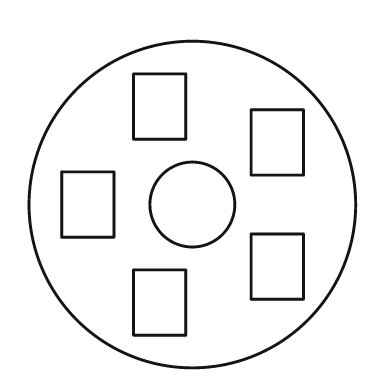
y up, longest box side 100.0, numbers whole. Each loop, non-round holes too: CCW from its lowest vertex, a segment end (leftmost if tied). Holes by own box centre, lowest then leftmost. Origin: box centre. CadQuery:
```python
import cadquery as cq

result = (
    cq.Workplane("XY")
    .moveTo(0.0, 0.0)
    .circle(50.0)
    .moveTo(-18.0, -40.0)
    .lineTo(-2.0, -40.0)
    .lineTo(-2.0, -20.0)
    .lineTo(-18.0, -20.0)
    .close()
    .moveTo(18.0, -29.0)
    .lineTo(34.0, -29.0)
    .lineTo(34.0, -9.0)
    .lineTo(18.0, -9.0)
    .close()
    .moveTo(-40.0, -10.0)
    .lineTo(-24.0, -10.0)
    .lineTo(-24.0, 10.0)
    .lineTo(-40.0, 10.0)
    .close()
    .moveTo(0.0, 0.0)
    .circle(13.0)
    .moveTo(18.0, 9.0)
    .lineTo(34.0, 9.0)
    .lineTo(34.0, 29.0)
    .lineTo(18.0, 29.0)
    .close()
    .moveTo(-18.0, 20.0)
    .lineTo(-2.0, 20.0)
    .lineTo(-2.0, 40.0)
    .lineTo(-18.0, 40.0)
    .close()
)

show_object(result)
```